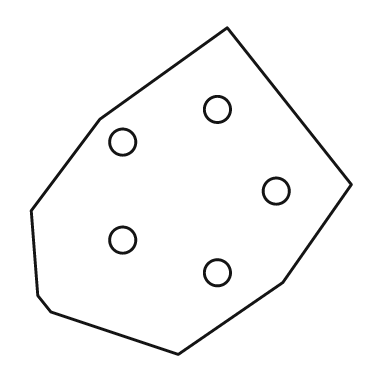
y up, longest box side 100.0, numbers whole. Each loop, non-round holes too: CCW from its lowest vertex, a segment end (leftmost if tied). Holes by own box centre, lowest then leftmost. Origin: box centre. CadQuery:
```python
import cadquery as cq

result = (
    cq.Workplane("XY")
    .moveTo(-4.0, -50.0)
    .lineTo(28.0, -28.0)
    .lineTo(49.0, 2.0)
    .lineTo(11.0, 50.0)
    .lineTo(-28.0, 22.0)
    .lineTo(-49.0, -6.0)
    .lineTo(-47.0, -32.0)
    .lineTo(-43.0, -37.0)
    .close()
    .moveTo(8.0, -25.0)
    .circle(4.0)
    .moveTo(-21.0, -15.0)
    .circle(4.0)
    .moveTo(26.0, 0.0)
    .circle(4.0)
    .moveTo(-21.0, 15.0)
    .circle(4.0)
    .moveTo(8.0, 25.0)
    .circle(4.0)
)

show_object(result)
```